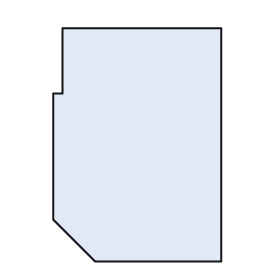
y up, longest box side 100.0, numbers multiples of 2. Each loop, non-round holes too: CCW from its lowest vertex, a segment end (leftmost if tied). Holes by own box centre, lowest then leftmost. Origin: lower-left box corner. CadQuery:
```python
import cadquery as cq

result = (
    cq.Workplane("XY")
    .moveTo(18.0, 0.0)
    .lineTo(72.0, 0.0)
    .lineTo(72.0, 100.0)
    .lineTo(4.0, 100.0)
    .lineTo(4.0, 72.0)
    .lineTo(0.0, 72.0)
    .lineTo(0.0, 18.0)
    .close()
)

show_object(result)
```